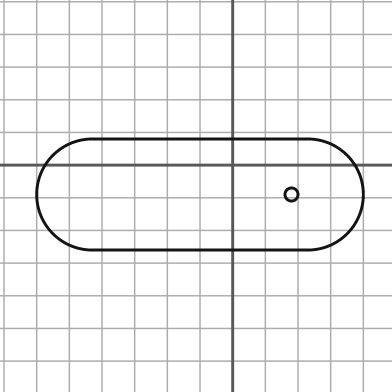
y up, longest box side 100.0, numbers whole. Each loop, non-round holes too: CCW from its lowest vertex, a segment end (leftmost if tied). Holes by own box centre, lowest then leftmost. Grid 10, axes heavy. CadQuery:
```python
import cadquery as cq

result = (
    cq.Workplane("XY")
    .moveTo(-43.0, -26.0)
    .lineTo(23.0, -26.0)
    .threePointArc((40.0, -9.0), (23.0, 8.0))
    .lineTo(-43.0, 8.0)
    .threePointArc((-60.0, -9.0), (-43.0, -26.0))
    .close()
    .moveTo(18.0, -9.0)
    .circle(2.0)
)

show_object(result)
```